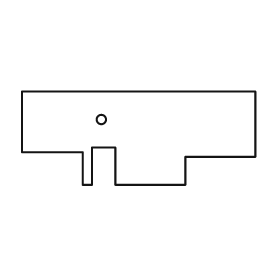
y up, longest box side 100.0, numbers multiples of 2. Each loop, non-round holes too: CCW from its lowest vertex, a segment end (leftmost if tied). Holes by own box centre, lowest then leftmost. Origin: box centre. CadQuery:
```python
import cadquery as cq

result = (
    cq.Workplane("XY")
    .moveTo(-24.0, -20.0)
    .lineTo(-20.0, -20.0)
    .lineTo(-20.0, -4.0)
    .lineTo(-10.0, -4.0)
    .lineTo(-10.0, -20.0)
    .lineTo(20.0, -20.0)
    .lineTo(20.0, -8.0)
    .lineTo(50.0, -8.0)
    .lineTo(50.0, 20.0)
    .lineTo(-50.0, 20.0)
    .lineTo(-50.0, -6.0)
    .lineTo(-24.0, -6.0)
    .close()
    .moveTo(-16.0, 8.0)
    .circle(2.0)
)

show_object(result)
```